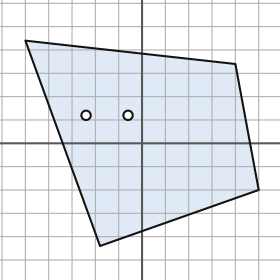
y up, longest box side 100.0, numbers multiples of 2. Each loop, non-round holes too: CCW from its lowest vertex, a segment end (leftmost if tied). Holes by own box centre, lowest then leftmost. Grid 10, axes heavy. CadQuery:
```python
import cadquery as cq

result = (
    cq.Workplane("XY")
    .moveTo(-18.0, -44.0)
    .lineTo(50.0, -20.0)
    .lineTo(40.0, 34.0)
    .lineTo(-50.0, 44.0)
    .close()
    .moveTo(-24.0, 12.0)
    .circle(2.0)
    .moveTo(-6.0, 12.0)
    .circle(2.0)
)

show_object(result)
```